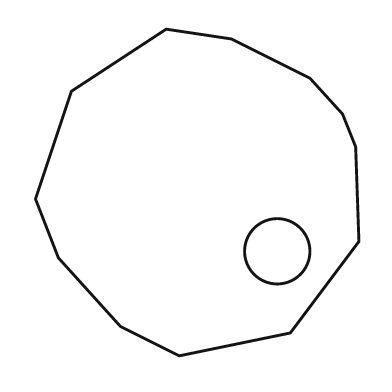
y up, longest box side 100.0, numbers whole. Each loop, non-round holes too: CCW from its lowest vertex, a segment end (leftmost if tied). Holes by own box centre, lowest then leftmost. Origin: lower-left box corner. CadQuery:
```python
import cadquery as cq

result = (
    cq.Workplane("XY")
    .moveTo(44.0, 0.0)
    .lineTo(78.0, 7.0)
    .lineTo(99.0, 35.0)
    .lineTo(98.0, 64.0)
    .lineTo(94.0, 74.0)
    .lineTo(84.0, 85.0)
    .lineTo(60.0, 97.0)
    .lineTo(40.0, 100.0)
    .lineTo(11.0, 81.0)
    .lineTo(0.0, 48.0)
    .lineTo(7.0, 30.0)
    .lineTo(26.0, 9.0)
    .close()
    .moveTo(74.0, 32.0)
    .circle(10.0)
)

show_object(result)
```